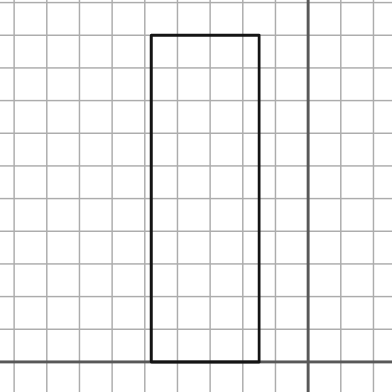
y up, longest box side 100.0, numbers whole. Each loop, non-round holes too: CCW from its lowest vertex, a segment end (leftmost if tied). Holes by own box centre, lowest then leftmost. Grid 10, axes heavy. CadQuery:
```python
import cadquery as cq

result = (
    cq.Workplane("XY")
    .moveTo(-48.0, 0.0)
    .lineTo(-15.0, 0.0)
    .lineTo(-15.0, 100.0)
    .lineTo(-48.0, 100.0)
    .close()
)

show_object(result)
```